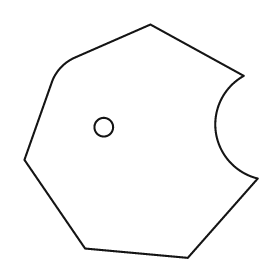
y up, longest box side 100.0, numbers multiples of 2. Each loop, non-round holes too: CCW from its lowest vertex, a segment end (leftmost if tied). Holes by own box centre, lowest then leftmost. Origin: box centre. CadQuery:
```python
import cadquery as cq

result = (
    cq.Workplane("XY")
    .moveTo(20.0, -50.0)
    .lineTo(50.0, -16.0)
    .threePointArc((32.0, 4.0), (44.0, 28.0))
    .lineTo(4.0, 50.0)
    .lineTo(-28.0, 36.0)
    .threePointArc((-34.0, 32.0), (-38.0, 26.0))
    .lineTo(-50.0, -8.0)
    .lineTo(-24.0, -46.0)
    .close()
    .moveTo(-16.0, 6.0)
    .circle(4.0)
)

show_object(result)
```